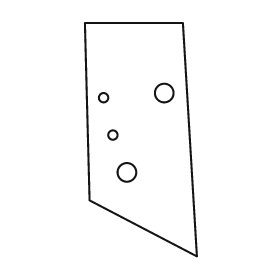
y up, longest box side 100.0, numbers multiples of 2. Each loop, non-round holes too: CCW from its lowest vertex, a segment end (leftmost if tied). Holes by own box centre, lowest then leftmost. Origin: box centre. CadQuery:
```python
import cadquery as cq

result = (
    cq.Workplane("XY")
    .moveTo(24.0, -50.0)
    .lineTo(18.0, 50.0)
    .lineTo(-24.0, 50.0)
    .lineTo(-22.0, -26.0)
    .close()
    .moveTo(-6.0, -14.0)
    .circle(4.0)
    .moveTo(-12.0, 2.0)
    .circle(2.0)
    .moveTo(-16.0, 18.0)
    .circle(2.0)
    .moveTo(10.0, 20.0)
    .circle(4.0)
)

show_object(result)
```